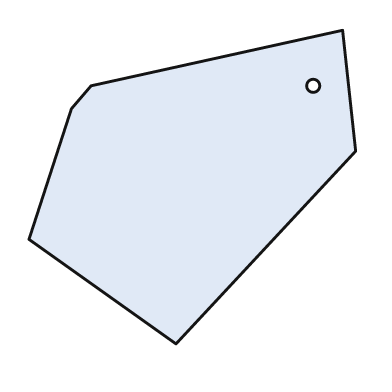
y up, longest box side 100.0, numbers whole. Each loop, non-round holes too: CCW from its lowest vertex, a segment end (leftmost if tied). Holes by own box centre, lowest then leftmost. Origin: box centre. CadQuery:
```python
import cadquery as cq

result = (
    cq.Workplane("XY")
    .moveTo(-5.0, -48.0)
    .lineTo(50.0, 11.0)
    .lineTo(46.0, 48.0)
    .lineTo(-31.0, 31.0)
    .lineTo(-37.0, 24.0)
    .lineTo(-50.0, -16.0)
    .close()
    .moveTo(37.0, 31.0)
    .circle(2.0)
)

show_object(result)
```